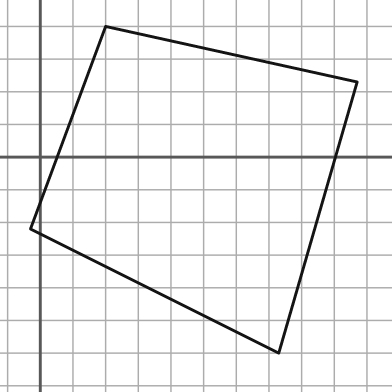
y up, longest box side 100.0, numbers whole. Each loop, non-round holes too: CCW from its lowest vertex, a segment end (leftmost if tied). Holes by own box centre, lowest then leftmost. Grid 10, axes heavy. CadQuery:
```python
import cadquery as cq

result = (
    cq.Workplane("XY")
    .moveTo(73.0, -60.0)
    .lineTo(97.0, 23.0)
    .lineTo(20.0, 40.0)
    .lineTo(-3.0, -22.0)
    .close()
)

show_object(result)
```